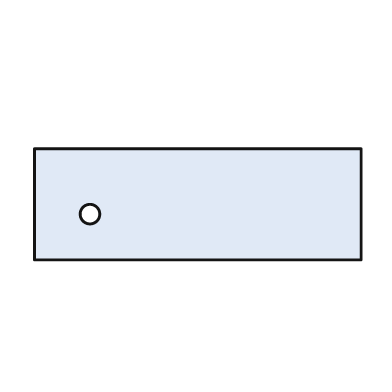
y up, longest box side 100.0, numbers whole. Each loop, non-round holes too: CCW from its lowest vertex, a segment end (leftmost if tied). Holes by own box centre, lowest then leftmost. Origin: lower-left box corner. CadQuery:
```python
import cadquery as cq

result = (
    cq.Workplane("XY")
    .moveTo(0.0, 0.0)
    .lineTo(100.0, 0.0)
    .lineTo(100.0, 34.0)
    .lineTo(0.0, 34.0)
    .close()
    .moveTo(17.0, 14.0)
    .circle(3.0)
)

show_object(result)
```